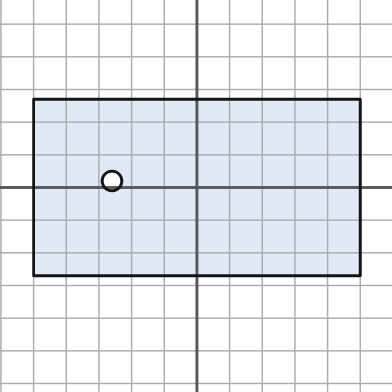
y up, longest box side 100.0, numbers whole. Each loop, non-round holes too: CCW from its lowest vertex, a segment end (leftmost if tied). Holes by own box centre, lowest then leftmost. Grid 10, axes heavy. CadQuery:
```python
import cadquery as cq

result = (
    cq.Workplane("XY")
    .moveTo(-50.0, -27.0)
    .lineTo(50.0, -27.0)
    .lineTo(50.0, 27.0)
    .lineTo(-50.0, 27.0)
    .close()
    .moveTo(-26.0, 2.0)
    .circle(3.0)
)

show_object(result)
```